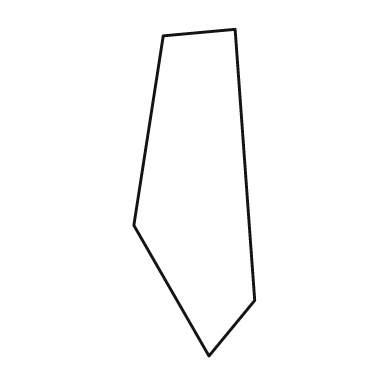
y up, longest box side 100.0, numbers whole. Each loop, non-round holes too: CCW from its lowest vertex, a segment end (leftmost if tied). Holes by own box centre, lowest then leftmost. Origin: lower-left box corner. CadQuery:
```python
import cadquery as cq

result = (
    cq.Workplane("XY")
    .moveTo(23.0, 0.0)
    .lineTo(37.0, 17.0)
    .lineTo(31.0, 100.0)
    .lineTo(9.0, 98.0)
    .lineTo(0.0, 40.0)
    .close()
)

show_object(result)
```